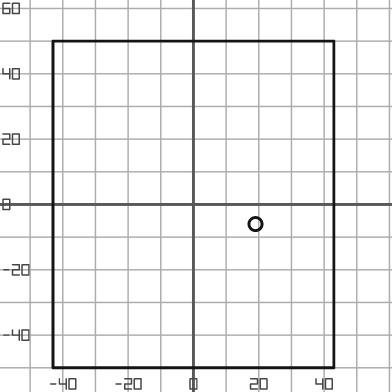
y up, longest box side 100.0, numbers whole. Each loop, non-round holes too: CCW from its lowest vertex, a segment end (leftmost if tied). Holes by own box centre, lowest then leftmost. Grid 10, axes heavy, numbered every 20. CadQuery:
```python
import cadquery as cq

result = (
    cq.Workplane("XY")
    .moveTo(-43.0, -50.0)
    .lineTo(43.0, -50.0)
    .lineTo(43.0, 50.0)
    .lineTo(-43.0, 50.0)
    .close()
    .moveTo(19.0, -6.0)
    .circle(2.0)
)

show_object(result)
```